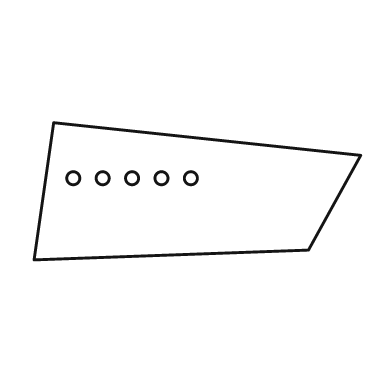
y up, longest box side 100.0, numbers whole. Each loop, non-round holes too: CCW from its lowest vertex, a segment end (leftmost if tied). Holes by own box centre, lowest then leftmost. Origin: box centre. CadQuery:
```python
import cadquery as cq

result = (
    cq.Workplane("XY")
    .moveTo(-50.0, -21.0)
    .lineTo(34.0, -18.0)
    .lineTo(50.0, 11.0)
    .lineTo(-44.0, 21.0)
    .close()
    .moveTo(-38.0, 4.0)
    .circle(2.0)
    .moveTo(-29.0, 4.0)
    .circle(2.0)
    .moveTo(-20.0, 4.0)
    .circle(2.0)
    .moveTo(-11.0, 4.0)
    .circle(2.0)
    .moveTo(-2.0, 4.0)
    .circle(2.0)
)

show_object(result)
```